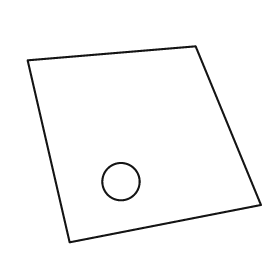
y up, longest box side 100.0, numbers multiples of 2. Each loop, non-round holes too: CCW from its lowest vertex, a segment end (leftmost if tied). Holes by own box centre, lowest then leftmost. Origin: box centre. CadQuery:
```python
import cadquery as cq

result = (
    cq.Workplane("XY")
    .moveTo(-32.0, -42.0)
    .lineTo(50.0, -26.0)
    .lineTo(22.0, 42.0)
    .lineTo(-50.0, 36.0)
    .close()
    .moveTo(-10.0, -16.0)
    .circle(8.0)
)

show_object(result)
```